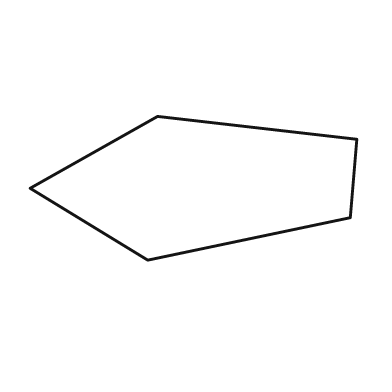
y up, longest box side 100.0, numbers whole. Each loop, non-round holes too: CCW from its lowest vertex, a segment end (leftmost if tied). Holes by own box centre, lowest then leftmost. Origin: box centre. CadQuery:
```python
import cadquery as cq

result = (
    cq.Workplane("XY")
    .moveTo(-14.0, -22.0)
    .lineTo(48.0, -9.0)
    .lineTo(50.0, 15.0)
    .lineTo(-11.0, 22.0)
    .lineTo(-50.0, 0.0)
    .close()
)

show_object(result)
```